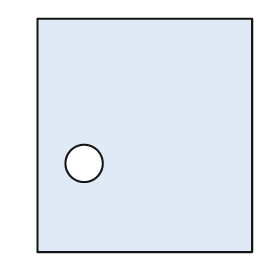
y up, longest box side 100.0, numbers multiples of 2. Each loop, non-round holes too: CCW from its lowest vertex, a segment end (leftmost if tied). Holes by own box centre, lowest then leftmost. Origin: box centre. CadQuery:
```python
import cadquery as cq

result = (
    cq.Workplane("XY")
    .moveTo(-46.0, -50.0)
    .lineTo(46.0, -50.0)
    .lineTo(46.0, 50.0)
    .lineTo(-46.0, 50.0)
    .close()
    .moveTo(-26.0, -12.0)
    .circle(8.0)
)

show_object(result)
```